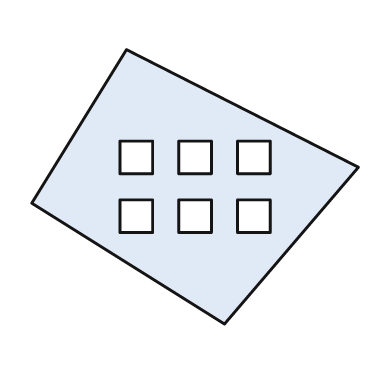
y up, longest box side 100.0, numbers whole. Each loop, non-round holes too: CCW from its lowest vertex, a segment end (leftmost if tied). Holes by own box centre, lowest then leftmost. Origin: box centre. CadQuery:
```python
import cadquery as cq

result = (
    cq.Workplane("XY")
    .moveTo(9.0, -42.0)
    .lineTo(50.0, 6.0)
    .lineTo(-21.0, 42.0)
    .lineTo(-50.0, -5.0)
    .close()
    .moveTo(-23.0, -14.0)
    .lineTo(-13.0, -14.0)
    .lineTo(-13.0, -4.0)
    .lineTo(-23.0, -4.0)
    .close()
    .moveTo(-5.0, -14.0)
    .lineTo(5.0, -14.0)
    .lineTo(5.0, -4.0)
    .lineTo(-5.0, -4.0)
    .close()
    .moveTo(13.0, -14.0)
    .lineTo(23.0, -14.0)
    .lineTo(23.0, -4.0)
    .lineTo(13.0, -4.0)
    .close()
    .moveTo(-23.0, 4.0)
    .lineTo(-13.0, 4.0)
    .lineTo(-13.0, 14.0)
    .lineTo(-23.0, 14.0)
    .close()
    .moveTo(-5.0, 4.0)
    .lineTo(5.0, 4.0)
    .lineTo(5.0, 14.0)
    .lineTo(-5.0, 14.0)
    .close()
    .moveTo(13.0, 4.0)
    .lineTo(23.0, 4.0)
    .lineTo(23.0, 14.0)
    .lineTo(13.0, 14.0)
    .close()
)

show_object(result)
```